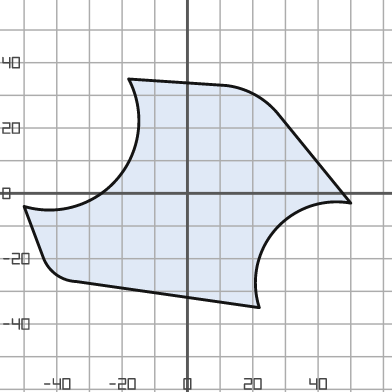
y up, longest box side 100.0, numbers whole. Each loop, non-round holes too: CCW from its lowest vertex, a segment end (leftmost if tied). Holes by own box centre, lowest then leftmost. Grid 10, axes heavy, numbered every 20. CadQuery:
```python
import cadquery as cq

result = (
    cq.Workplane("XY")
    .moveTo(22.0, -35.0)
    .threePointArc((27.0, -11.0), (50.0, -3.0))
    .lineTo(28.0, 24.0)
    .threePointArc((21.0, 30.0), (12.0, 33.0))
    .lineTo(-18.0, 35.0)
    .threePointArc((-21.0, 5.0), (-50.0, -4.0))
    .lineTo(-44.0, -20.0)
    .threePointArc((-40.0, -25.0), (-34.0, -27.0))
    .close()
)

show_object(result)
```